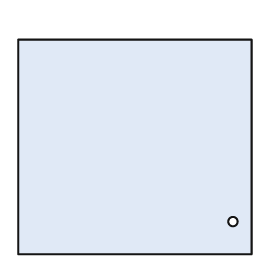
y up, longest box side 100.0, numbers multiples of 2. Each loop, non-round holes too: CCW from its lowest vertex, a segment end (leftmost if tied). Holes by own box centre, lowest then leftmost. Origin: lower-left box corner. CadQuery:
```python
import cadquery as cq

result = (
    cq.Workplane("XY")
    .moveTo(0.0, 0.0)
    .lineTo(100.0, 0.0)
    .lineTo(100.0, 92.0)
    .lineTo(0.0, 92.0)
    .close()
    .moveTo(92.0, 14.0)
    .circle(2.0)
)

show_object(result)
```